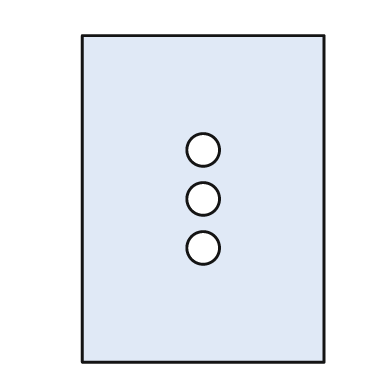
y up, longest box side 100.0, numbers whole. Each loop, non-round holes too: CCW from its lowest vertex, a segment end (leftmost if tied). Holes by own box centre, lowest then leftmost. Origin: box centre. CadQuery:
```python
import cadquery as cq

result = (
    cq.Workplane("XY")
    .moveTo(-37.0, -50.0)
    .lineTo(37.0, -50.0)
    .lineTo(37.0, 50.0)
    .lineTo(-37.0, 50.0)
    .close()
    .moveTo(0.0, -15.0)
    .circle(5.0)
    .moveTo(0.0, 0.0)
    .circle(5.0)
    .moveTo(0.0, 15.0)
    .circle(5.0)
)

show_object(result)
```